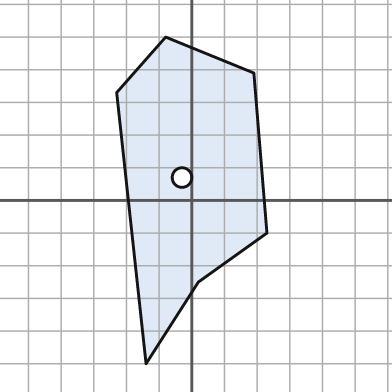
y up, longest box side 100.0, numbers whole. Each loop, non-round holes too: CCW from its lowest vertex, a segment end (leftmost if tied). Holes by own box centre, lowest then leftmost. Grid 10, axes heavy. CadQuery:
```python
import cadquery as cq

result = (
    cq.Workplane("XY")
    .moveTo(-14.0, -50.0)
    .lineTo(2.0, -25.0)
    .lineTo(23.0, -10.0)
    .lineTo(19.0, 39.0)
    .lineTo(-8.0, 50.0)
    .lineTo(-23.0, 33.0)
    .close()
    .moveTo(-3.0, 7.0)
    .circle(3.0)
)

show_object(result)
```